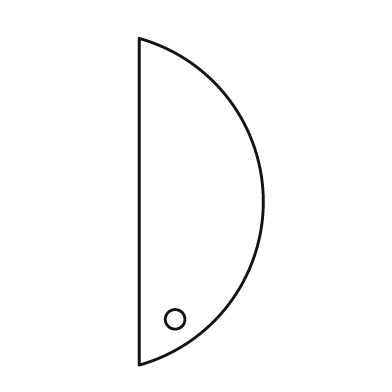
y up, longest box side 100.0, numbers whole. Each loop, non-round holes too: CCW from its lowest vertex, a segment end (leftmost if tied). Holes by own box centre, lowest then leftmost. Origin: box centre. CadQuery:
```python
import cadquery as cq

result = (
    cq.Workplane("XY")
    .moveTo(-19.0, -50.0)
    .threePointArc((19.0, 0.0), (-19.0, 50.0))
    .close()
    .moveTo(-8.0, -36.0)
    .circle(3.0)
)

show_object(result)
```